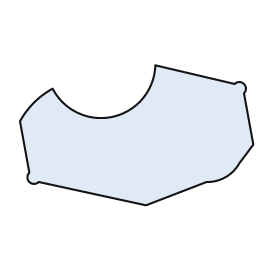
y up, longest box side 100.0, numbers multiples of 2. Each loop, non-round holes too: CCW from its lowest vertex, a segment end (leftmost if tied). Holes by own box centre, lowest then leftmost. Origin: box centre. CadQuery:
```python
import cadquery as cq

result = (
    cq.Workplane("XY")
    .moveTo(4.0, -30.0)
    .lineTo(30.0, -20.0)
    .threePointArc((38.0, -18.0), (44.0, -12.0))
    .lineTo(50.0, -4.0)
    .lineTo(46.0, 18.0)
    .threePointArc((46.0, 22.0), (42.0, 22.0))
    .lineTo(8.0, 30.0)
    .threePointArc((-10.0, 8.0), (-36.0, 20.0))
    .threePointArc((-44.0, 14.0), (-50.0, 6.0))
    .lineTo(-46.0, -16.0)
    .threePointArc((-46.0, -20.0), (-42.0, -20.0))
    .close()
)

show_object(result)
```